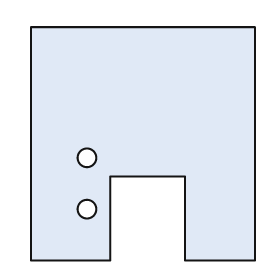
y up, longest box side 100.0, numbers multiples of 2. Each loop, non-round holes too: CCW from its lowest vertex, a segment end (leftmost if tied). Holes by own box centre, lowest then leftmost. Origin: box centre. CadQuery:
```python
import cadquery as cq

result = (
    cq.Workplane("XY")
    .moveTo(-48.0, -50.0)
    .lineTo(-14.0, -50.0)
    .lineTo(-14.0, -14.0)
    .lineTo(18.0, -14.0)
    .lineTo(18.0, -50.0)
    .lineTo(48.0, -50.0)
    .lineTo(48.0, 50.0)
    .lineTo(-48.0, 50.0)
    .close()
    .moveTo(-24.0, -28.0)
    .circle(4.0)
    .moveTo(-24.0, -6.0)
    .circle(4.0)
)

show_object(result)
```